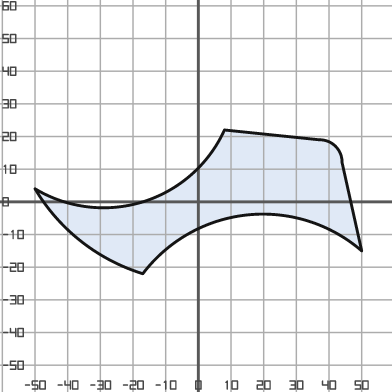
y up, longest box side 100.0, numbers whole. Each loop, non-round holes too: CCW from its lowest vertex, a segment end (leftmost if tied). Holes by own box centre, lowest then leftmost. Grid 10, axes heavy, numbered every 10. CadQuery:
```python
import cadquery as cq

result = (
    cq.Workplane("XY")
    .moveTo(-17.0, -22.0)
    .threePointArc((15.0, -4.0), (50.0, -15.0))
    .lineTo(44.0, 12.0)
    .threePointArc((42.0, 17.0), (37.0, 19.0))
    .lineTo(8.0, 22.0)
    .threePointArc((-17.0, 0.0), (-50.0, 4.0))
    .threePointArc((-36.0, -12.0), (-17.0, -22.0))
    .close()
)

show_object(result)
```